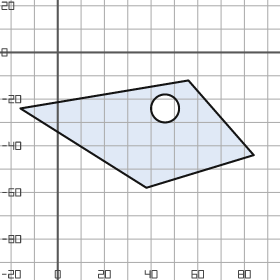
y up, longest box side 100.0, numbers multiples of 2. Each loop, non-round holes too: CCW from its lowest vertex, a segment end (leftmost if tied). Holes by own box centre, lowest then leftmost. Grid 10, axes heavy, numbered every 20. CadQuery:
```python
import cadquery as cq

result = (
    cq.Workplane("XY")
    .moveTo(38.0, -58.0)
    .lineTo(84.0, -44.0)
    .lineTo(56.0, -12.0)
    .lineTo(-16.0, -24.0)
    .close()
    .moveTo(46.0, -24.0)
    .circle(6.0)
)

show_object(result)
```